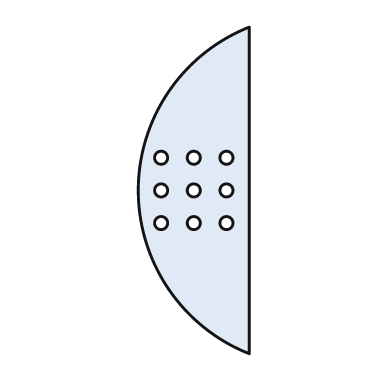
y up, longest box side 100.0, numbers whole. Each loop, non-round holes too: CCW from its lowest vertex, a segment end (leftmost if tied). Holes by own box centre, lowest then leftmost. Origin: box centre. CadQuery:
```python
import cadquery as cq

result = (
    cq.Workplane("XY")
    .moveTo(17.0, -50.0)
    .lineTo(17.0, 50.0)
    .threePointArc((-17.0, 0.0), (17.0, -50.0))
    .close()
    .moveTo(-10.0, -10.0)
    .circle(2.0)
    .moveTo(0.0, -10.0)
    .circle(2.0)
    .moveTo(10.0, -10.0)
    .circle(2.0)
    .moveTo(-10.0, 0.0)
    .circle(2.0)
    .moveTo(0.0, 0.0)
    .circle(2.0)
    .moveTo(10.0, 0.0)
    .circle(2.0)
    .moveTo(-10.0, 10.0)
    .circle(2.0)
    .moveTo(0.0, 10.0)
    .circle(2.0)
    .moveTo(10.0, 10.0)
    .circle(2.0)
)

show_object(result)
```